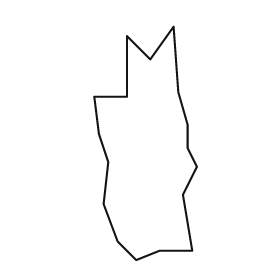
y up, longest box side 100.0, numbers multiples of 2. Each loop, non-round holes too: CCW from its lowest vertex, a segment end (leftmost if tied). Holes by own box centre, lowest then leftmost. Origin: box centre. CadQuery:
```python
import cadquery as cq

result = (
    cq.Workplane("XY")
    .moveTo(-4.0, -50.0)
    .lineTo(6.0, -46.0)
    .lineTo(20.0, -46.0)
    .lineTo(16.0, -22.0)
    .lineTo(22.0, -10.0)
    .lineTo(18.0, -2.0)
    .lineTo(18.0, 8.0)
    .lineTo(14.0, 22.0)
    .lineTo(12.0, 50.0)
    .lineTo(2.0, 36.0)
    .lineTo(-8.0, 46.0)
    .lineTo(-8.0, 20.0)
    .lineTo(-22.0, 20.0)
    .lineTo(-20.0, 4.0)
    .lineTo(-16.0, -8.0)
    .lineTo(-18.0, -26.0)
    .lineTo(-12.0, -42.0)
    .close()
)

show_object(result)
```